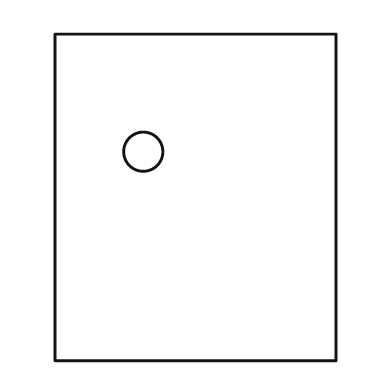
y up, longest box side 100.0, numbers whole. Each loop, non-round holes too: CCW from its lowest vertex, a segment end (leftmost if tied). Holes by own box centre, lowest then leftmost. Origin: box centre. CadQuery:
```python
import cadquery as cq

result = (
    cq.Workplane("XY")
    .moveTo(-43.0, -50.0)
    .lineTo(43.0, -50.0)
    .lineTo(43.0, 50.0)
    .lineTo(-43.0, 50.0)
    .close()
    .moveTo(-16.0, 14.0)
    .circle(6.0)
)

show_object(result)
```